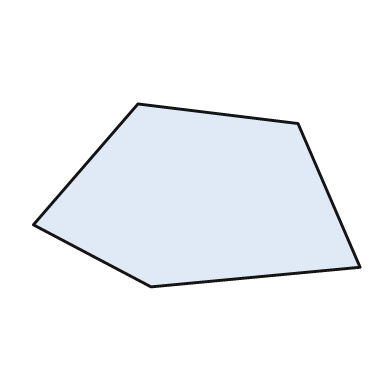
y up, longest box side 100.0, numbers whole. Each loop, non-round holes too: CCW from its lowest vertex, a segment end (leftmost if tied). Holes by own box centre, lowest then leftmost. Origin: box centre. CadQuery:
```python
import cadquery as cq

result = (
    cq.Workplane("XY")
    .moveTo(-14.0, -28.0)
    .lineTo(50.0, -22.0)
    .lineTo(31.0, 22.0)
    .lineTo(-18.0, 28.0)
    .lineTo(-50.0, -9.0)
    .close()
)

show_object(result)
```